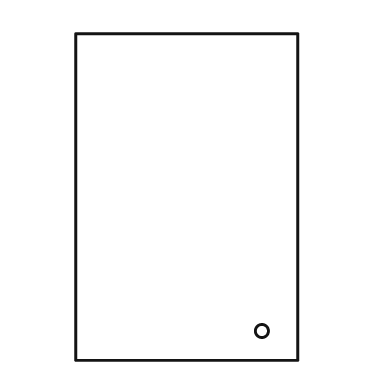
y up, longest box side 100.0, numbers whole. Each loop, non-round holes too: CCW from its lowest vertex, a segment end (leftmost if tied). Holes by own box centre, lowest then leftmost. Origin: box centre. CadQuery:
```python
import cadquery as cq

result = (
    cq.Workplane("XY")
    .moveTo(-34.0, -50.0)
    .lineTo(34.0, -50.0)
    .lineTo(34.0, 50.0)
    .lineTo(-34.0, 50.0)
    .close()
    .moveTo(23.0, -41.0)
    .circle(2.0)
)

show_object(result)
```